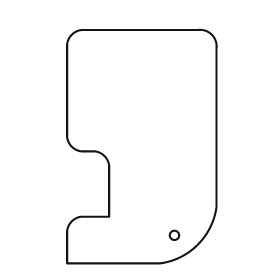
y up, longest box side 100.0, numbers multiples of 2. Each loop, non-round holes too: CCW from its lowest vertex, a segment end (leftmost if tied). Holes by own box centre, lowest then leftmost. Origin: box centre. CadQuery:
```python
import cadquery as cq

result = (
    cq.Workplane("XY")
    .moveTo(-32.0, -50.0)
    .lineTo(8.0, -50.0)
    .threePointArc((24.0, -42.0), (32.0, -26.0))
    .lineTo(32.0, 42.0)
    .threePointArc((30.0, 48.0), (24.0, 50.0))
    .lineTo(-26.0, 50.0)
    .threePointArc((-30.0, 48.0), (-32.0, 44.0))
    .lineTo(-32.0, 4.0)
    .threePointArc((-30.0, 0.0), (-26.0, -2.0))
    .lineTo(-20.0, -2.0)
    .threePointArc((-16.0, -4.0), (-14.0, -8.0))
    .lineTo(-14.0, -30.0)
    .lineTo(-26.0, -30.0)
    .threePointArc((-30.0, -32.0), (-32.0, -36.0))
    .close()
    .moveTo(14.0, -38.0)
    .circle(2.0)
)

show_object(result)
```